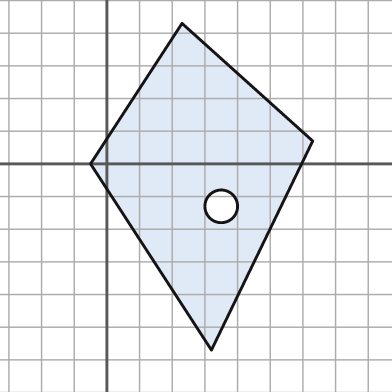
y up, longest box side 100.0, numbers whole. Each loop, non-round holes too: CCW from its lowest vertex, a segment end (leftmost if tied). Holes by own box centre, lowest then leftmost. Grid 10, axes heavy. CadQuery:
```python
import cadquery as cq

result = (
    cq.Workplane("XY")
    .moveTo(32.0, -57.0)
    .lineTo(63.0, 7.0)
    .lineTo(23.0, 43.0)
    .lineTo(-5.0, 0.0)
    .close()
    .moveTo(35.0, -13.0)
    .circle(5.0)
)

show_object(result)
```